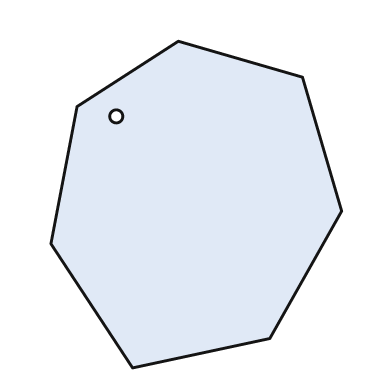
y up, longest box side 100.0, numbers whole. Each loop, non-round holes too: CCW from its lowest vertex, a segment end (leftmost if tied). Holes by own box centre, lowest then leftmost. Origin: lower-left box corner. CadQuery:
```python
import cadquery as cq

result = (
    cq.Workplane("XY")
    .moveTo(25.0, 0.0)
    .lineTo(67.0, 9.0)
    .lineTo(89.0, 48.0)
    .lineTo(77.0, 89.0)
    .lineTo(39.0, 100.0)
    .lineTo(8.0, 80.0)
    .lineTo(0.0, 38.0)
    .close()
    .moveTo(20.0, 77.0)
    .circle(2.0)
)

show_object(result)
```